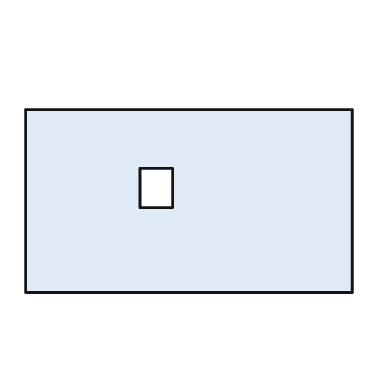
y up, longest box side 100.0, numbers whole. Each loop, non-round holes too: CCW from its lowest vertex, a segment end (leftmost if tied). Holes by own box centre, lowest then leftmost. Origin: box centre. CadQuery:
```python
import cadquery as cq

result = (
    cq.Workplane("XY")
    .moveTo(-50.0, -28.0)
    .lineTo(50.0, -28.0)
    .lineTo(50.0, 28.0)
    .lineTo(-50.0, 28.0)
    .close()
    .moveTo(-15.0, -2.0)
    .lineTo(-5.0, -2.0)
    .lineTo(-5.0, 10.0)
    .lineTo(-15.0, 10.0)
    .close()
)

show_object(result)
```